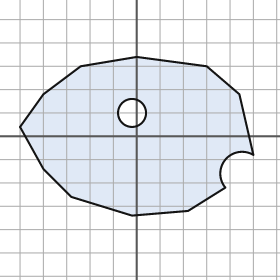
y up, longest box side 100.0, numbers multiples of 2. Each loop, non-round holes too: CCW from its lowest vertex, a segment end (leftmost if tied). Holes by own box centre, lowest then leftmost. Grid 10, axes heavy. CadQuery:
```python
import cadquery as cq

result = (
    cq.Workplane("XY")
    .moveTo(-2.0, -34.0)
    .lineTo(22.0, -32.0)
    .lineTo(38.0, -22.0)
    .threePointArc((38.0, -10.0), (50.0, -8.0))
    .lineTo(44.0, 18.0)
    .lineTo(30.0, 30.0)
    .lineTo(0.0, 34.0)
    .lineTo(-24.0, 30.0)
    .lineTo(-40.0, 18.0)
    .lineTo(-50.0, 4.0)
    .lineTo(-40.0, -14.0)
    .lineTo(-28.0, -26.0)
    .close()
    .moveTo(-2.0, 10.0)
    .circle(6.0)
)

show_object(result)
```